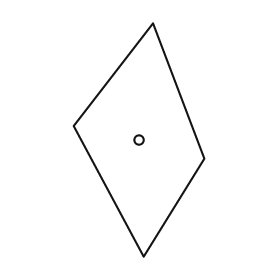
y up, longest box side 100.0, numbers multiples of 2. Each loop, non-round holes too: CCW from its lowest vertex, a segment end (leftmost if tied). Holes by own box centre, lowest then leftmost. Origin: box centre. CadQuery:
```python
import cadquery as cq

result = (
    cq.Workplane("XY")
    .moveTo(2.0, -50.0)
    .lineTo(28.0, -8.0)
    .lineTo(6.0, 50.0)
    .lineTo(-28.0, 6.0)
    .close()
    .moveTo(0.0, 0.0)
    .circle(2.0)
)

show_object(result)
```